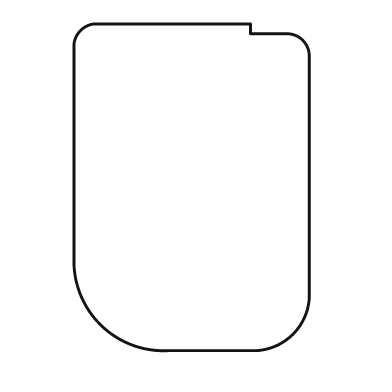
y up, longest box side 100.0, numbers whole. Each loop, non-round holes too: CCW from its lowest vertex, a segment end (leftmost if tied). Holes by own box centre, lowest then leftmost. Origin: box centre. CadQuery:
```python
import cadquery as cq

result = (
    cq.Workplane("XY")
    .moveTo(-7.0, -50.0)
    .lineTo(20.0, -50.0)
    .threePointArc((31.0, -45.0), (36.0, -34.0))
    .lineTo(36.0, 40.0)
    .threePointArc((34.0, 45.0), (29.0, 47.0))
    .lineTo(18.0, 47.0)
    .lineTo(18.0, 50.0)
    .lineTo(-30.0, 50.0)
    .threePointArc((-34.0, 48.0), (-36.0, 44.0))
    .lineTo(-36.0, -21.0)
    .threePointArc((-28.0, -42.0), (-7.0, -50.0))
    .close()
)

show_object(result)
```